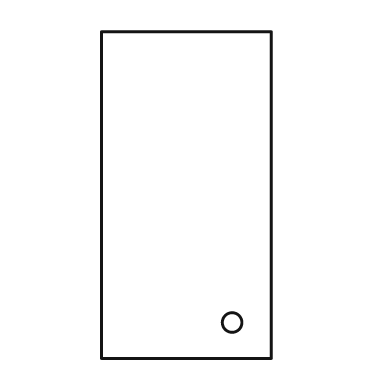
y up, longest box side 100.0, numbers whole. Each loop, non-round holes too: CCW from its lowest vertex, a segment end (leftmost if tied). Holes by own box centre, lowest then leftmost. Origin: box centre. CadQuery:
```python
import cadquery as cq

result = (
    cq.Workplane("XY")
    .moveTo(-26.0, -50.0)
    .lineTo(26.0, -50.0)
    .lineTo(26.0, 50.0)
    .lineTo(-26.0, 50.0)
    .close()
    .moveTo(14.0, -39.0)
    .circle(3.0)
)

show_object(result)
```